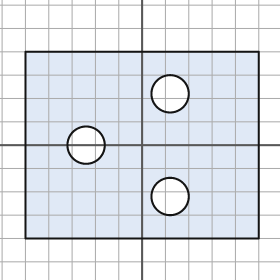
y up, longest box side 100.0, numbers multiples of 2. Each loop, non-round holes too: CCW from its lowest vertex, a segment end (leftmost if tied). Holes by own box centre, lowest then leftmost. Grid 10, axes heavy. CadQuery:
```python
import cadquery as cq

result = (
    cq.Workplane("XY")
    .moveTo(-50.0, -40.0)
    .lineTo(50.0, -40.0)
    .lineTo(50.0, 40.0)
    .lineTo(-50.0, 40.0)
    .close()
    .moveTo(12.0, -22.0)
    .circle(8.0)
    .moveTo(-24.0, 0.0)
    .circle(8.0)
    .moveTo(12.0, 22.0)
    .circle(8.0)
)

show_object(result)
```